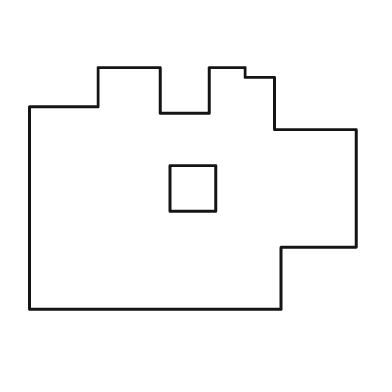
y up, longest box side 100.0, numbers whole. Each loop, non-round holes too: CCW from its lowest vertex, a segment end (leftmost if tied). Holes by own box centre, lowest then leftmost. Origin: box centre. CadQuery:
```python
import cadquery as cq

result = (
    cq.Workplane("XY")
    .moveTo(-50.0, -37.0)
    .lineTo(27.0, -37.0)
    .lineTo(27.0, -18.0)
    .lineTo(50.0, -18.0)
    .lineTo(50.0, 18.0)
    .lineTo(25.0, 18.0)
    .lineTo(25.0, 34.0)
    .lineTo(16.0, 34.0)
    .lineTo(16.0, 37.0)
    .lineTo(5.0, 37.0)
    .lineTo(5.0, 23.0)
    .lineTo(-10.0, 23.0)
    .lineTo(-10.0, 37.0)
    .lineTo(-29.0, 37.0)
    .lineTo(-29.0, 25.0)
    .lineTo(-50.0, 25.0)
    .close()
    .moveTo(-7.0, -7.0)
    .lineTo(7.0, -7.0)
    .lineTo(7.0, 7.0)
    .lineTo(-7.0, 7.0)
    .close()
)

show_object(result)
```